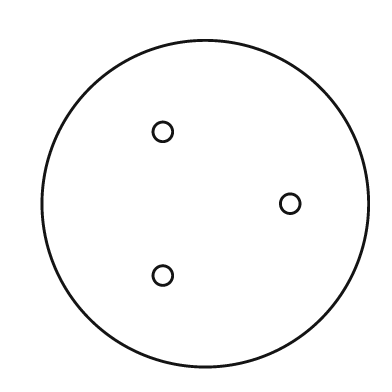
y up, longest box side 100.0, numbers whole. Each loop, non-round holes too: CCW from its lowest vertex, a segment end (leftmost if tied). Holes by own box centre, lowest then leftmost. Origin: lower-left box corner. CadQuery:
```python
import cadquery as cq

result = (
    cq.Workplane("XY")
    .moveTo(50.0, 50.0)
    .circle(50.0)
    .moveTo(37.0, 28.0)
    .circle(3.0)
    .moveTo(76.0, 50.0)
    .circle(3.0)
    .moveTo(37.0, 72.0)
    .circle(3.0)
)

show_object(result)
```